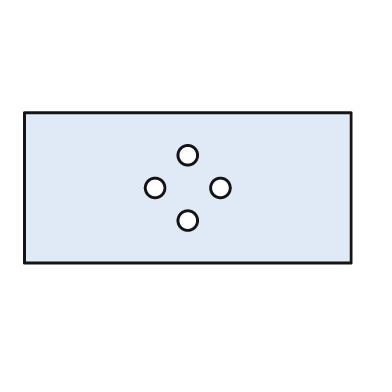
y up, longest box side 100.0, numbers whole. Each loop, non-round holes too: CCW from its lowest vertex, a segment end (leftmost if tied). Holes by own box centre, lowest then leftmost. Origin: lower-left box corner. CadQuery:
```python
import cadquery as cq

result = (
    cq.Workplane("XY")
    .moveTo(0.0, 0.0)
    .lineTo(100.0, 0.0)
    .lineTo(100.0, 46.0)
    .lineTo(0.0, 46.0)
    .close()
    .moveTo(50.0, 13.0)
    .circle(3.0)
    .moveTo(40.0, 23.0)
    .circle(3.0)
    .moveTo(60.0, 23.0)
    .circle(3.0)
    .moveTo(50.0, 33.0)
    .circle(3.0)
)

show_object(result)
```